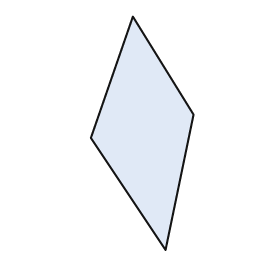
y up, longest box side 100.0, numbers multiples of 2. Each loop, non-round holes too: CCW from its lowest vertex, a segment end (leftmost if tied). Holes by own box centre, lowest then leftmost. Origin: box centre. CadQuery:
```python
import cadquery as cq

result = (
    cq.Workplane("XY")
    .moveTo(10.0, -50.0)
    .lineTo(22.0, 8.0)
    .lineTo(-4.0, 50.0)
    .lineTo(-22.0, -2.0)
    .close()
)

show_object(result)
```